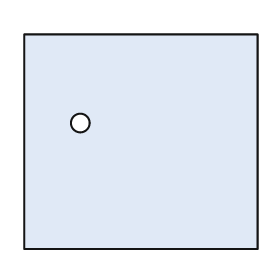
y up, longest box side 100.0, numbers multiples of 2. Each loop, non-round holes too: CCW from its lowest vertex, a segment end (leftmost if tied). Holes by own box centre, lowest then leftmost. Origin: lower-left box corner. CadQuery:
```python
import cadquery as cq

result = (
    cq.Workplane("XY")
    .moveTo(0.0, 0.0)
    .lineTo(100.0, 0.0)
    .lineTo(100.0, 92.0)
    .lineTo(0.0, 92.0)
    .close()
    .moveTo(24.0, 54.0)
    .circle(4.0)
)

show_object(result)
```